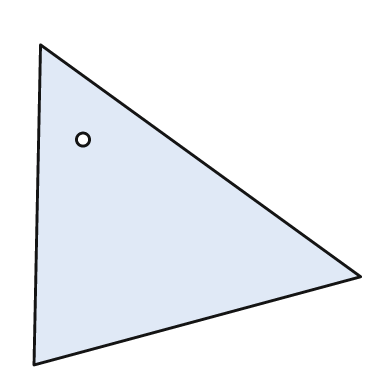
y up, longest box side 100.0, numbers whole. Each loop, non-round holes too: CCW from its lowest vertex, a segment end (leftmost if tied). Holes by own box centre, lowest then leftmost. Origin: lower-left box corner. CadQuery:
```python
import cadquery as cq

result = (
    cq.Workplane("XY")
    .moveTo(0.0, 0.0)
    .lineTo(100.0, 27.0)
    .lineTo(2.0, 98.0)
    .close()
    .moveTo(15.0, 69.0)
    .circle(2.0)
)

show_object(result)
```